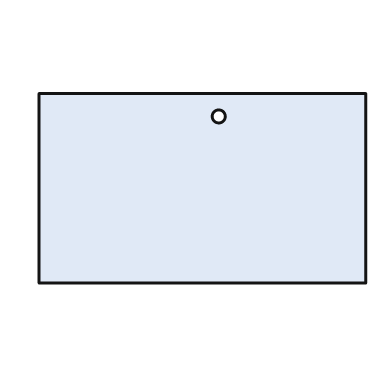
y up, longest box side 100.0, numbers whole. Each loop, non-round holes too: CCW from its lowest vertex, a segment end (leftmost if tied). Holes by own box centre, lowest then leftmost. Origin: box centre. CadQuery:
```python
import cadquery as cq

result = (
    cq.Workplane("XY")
    .moveTo(-50.0, -29.0)
    .lineTo(50.0, -29.0)
    .lineTo(50.0, 29.0)
    .lineTo(-50.0, 29.0)
    .close()
    .moveTo(5.0, 22.0)
    .circle(2.0)
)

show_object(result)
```